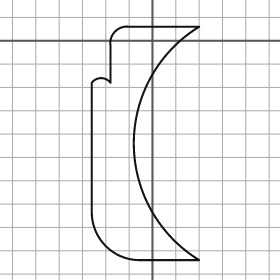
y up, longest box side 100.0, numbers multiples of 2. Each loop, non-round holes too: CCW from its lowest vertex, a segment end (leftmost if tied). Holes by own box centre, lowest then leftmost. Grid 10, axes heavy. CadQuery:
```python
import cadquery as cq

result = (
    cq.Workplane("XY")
    .moveTo(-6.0, -94.0)
    .lineTo(20.0, -94.0)
    .threePointArc((-8.0, -44.0), (20.0, 6.0))
    .lineTo(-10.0, 6.0)
    .threePointArc((-16.0, 4.0), (-18.0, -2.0))
    .lineTo(-18.0, -18.0)
    .threePointArc((-22.0, -16.0), (-26.0, -18.0))
    .lineTo(-26.0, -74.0)
    .threePointArc((-20.0, -88.0), (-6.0, -94.0))
    .close()
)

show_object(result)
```